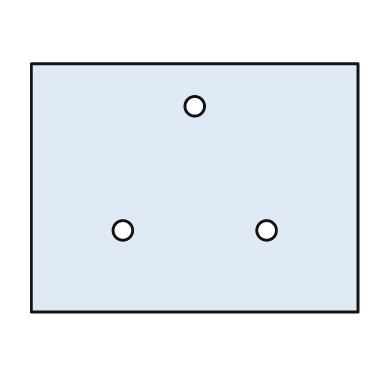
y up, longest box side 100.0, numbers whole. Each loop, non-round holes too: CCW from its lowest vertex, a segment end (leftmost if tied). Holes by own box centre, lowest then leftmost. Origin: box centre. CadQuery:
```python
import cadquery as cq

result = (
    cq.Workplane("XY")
    .moveTo(-50.0, -38.0)
    .lineTo(50.0, -38.0)
    .lineTo(50.0, 38.0)
    .lineTo(-50.0, 38.0)
    .close()
    .moveTo(-22.0, -13.0)
    .circle(3.0)
    .moveTo(22.0, -13.0)
    .circle(3.0)
    .moveTo(0.0, 25.0)
    .circle(3.0)
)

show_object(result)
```